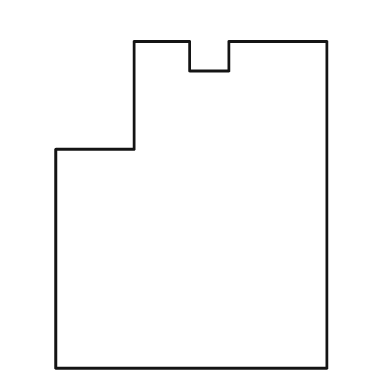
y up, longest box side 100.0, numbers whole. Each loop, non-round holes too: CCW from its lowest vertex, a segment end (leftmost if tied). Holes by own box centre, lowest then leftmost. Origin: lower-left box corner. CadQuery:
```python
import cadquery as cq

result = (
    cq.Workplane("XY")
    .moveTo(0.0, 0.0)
    .lineTo(83.0, 0.0)
    .lineTo(83.0, 100.0)
    .lineTo(53.0, 100.0)
    .lineTo(53.0, 91.0)
    .lineTo(41.0, 91.0)
    .lineTo(41.0, 100.0)
    .lineTo(24.0, 100.0)
    .lineTo(24.0, 67.0)
    .lineTo(0.0, 67.0)
    .close()
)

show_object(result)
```